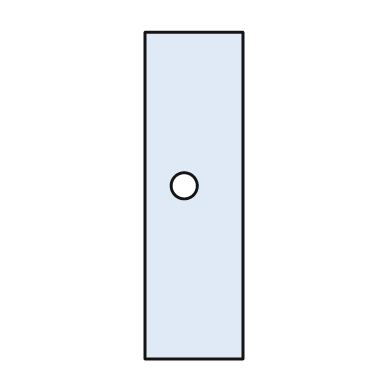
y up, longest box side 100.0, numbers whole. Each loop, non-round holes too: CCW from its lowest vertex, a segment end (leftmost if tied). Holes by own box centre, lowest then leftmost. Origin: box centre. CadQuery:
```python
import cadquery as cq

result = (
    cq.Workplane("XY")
    .moveTo(-15.0, -50.0)
    .lineTo(15.0, -50.0)
    .lineTo(15.0, 50.0)
    .lineTo(-15.0, 50.0)
    .close()
    .moveTo(-3.0, 3.0)
    .circle(4.0)
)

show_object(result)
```